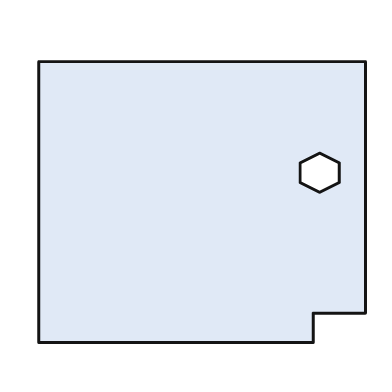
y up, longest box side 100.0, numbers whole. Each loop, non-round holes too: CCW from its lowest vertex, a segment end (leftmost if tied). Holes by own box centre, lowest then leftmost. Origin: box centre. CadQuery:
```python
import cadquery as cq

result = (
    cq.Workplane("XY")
    .moveTo(-50.0, -43.0)
    .lineTo(34.0, -43.0)
    .lineTo(34.0, -34.0)
    .lineTo(50.0, -34.0)
    .lineTo(50.0, 43.0)
    .lineTo(-50.0, 43.0)
    .close()
    .moveTo(36.0, 3.0)
    .lineTo(42.0, 6.0)
    .lineTo(42.0, 12.0)
    .lineTo(36.0, 15.0)
    .lineTo(30.0, 12.0)
    .lineTo(30.0, 6.0)
    .close()
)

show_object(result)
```